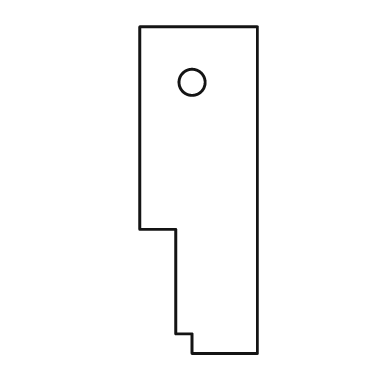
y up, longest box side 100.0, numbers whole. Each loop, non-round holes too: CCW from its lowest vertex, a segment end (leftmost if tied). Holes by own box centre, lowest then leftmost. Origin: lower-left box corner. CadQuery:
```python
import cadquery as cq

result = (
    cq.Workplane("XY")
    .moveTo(16.0, 0.0)
    .lineTo(36.0, 0.0)
    .lineTo(36.0, 100.0)
    .lineTo(0.0, 100.0)
    .lineTo(0.0, 38.0)
    .lineTo(11.0, 38.0)
    .lineTo(11.0, 6.0)
    .lineTo(16.0, 6.0)
    .close()
    .moveTo(16.0, 83.0)
    .circle(4.0)
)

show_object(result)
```